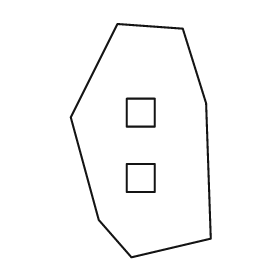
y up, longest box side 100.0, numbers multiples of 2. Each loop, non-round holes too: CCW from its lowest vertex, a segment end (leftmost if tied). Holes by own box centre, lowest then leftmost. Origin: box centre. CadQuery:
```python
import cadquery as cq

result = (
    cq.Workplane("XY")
    .moveTo(-4.0, -50.0)
    .lineTo(30.0, -42.0)
    .lineTo(28.0, 16.0)
    .lineTo(18.0, 48.0)
    .lineTo(-10.0, 50.0)
    .lineTo(-30.0, 10.0)
    .lineTo(-18.0, -34.0)
    .close()
    .moveTo(-6.0, -22.0)
    .lineTo(6.0, -22.0)
    .lineTo(6.0, -10.0)
    .lineTo(-6.0, -10.0)
    .close()
    .moveTo(-6.0, 6.0)
    .lineTo(6.0, 6.0)
    .lineTo(6.0, 18.0)
    .lineTo(-6.0, 18.0)
    .close()
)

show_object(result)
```